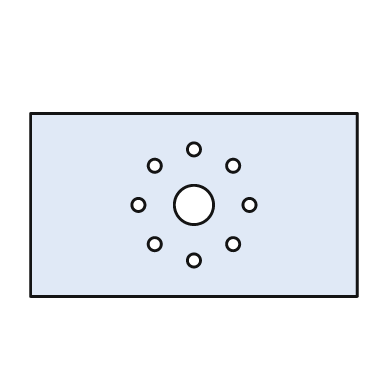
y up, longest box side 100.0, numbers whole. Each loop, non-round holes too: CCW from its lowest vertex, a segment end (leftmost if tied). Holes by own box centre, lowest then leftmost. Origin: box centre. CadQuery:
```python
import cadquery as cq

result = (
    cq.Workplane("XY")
    .moveTo(-50.0, -28.0)
    .lineTo(50.0, -28.0)
    .lineTo(50.0, 28.0)
    .lineTo(-50.0, 28.0)
    .close()
    .moveTo(0.0, -17.0)
    .circle(2.0)
    .moveTo(-12.0, -12.0)
    .circle(2.0)
    .moveTo(12.0, -12.0)
    .circle(2.0)
    .moveTo(-17.0, 0.0)
    .circle(2.0)
    .moveTo(0.0, 0.0)
    .circle(6.0)
    .moveTo(17.0, 0.0)
    .circle(2.0)
    .moveTo(-12.0, 12.0)
    .circle(2.0)
    .moveTo(12.0, 12.0)
    .circle(2.0)
    .moveTo(0.0, 17.0)
    .circle(2.0)
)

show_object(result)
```